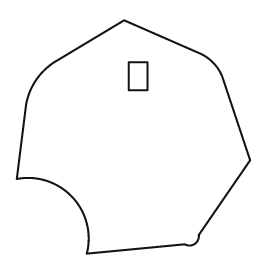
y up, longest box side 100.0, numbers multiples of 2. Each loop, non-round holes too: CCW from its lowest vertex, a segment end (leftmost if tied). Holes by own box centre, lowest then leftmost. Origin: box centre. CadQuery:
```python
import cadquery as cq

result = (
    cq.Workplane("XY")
    .moveTo(-20.0, -50.0)
    .lineTo(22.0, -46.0)
    .threePointArc((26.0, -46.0), (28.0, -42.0))
    .lineTo(50.0, -10.0)
    .lineTo(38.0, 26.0)
    .threePointArc((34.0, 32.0), (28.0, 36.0))
    .lineTo(-4.0, 50.0)
    .lineTo(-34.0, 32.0)
    .threePointArc((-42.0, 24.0), (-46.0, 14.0))
    .lineTo(-50.0, -18.0)
    .threePointArc((-26.0, -26.0), (-20.0, -50.0))
    .close()
    .moveTo(-2.0, 20.0)
    .lineTo(6.0, 20.0)
    .lineTo(6.0, 32.0)
    .lineTo(-2.0, 32.0)
    .close()
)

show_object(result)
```